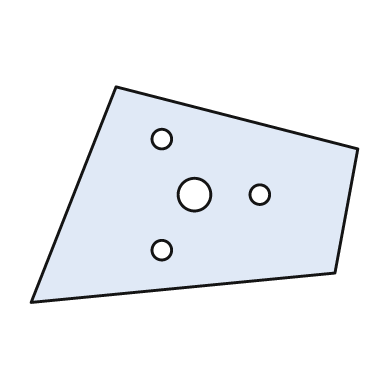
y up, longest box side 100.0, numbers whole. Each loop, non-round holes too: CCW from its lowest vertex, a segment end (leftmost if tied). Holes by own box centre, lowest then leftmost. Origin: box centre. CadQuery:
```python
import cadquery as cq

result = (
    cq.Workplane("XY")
    .moveTo(-50.0, -33.0)
    .lineTo(43.0, -24.0)
    .lineTo(50.0, 14.0)
    .lineTo(-24.0, 33.0)
    .close()
    .moveTo(-10.0, -17.0)
    .circle(3.0)
    .moveTo(0.0, 0.0)
    .circle(5.0)
    .moveTo(20.0, 0.0)
    .circle(3.0)
    .moveTo(-10.0, 17.0)
    .circle(3.0)
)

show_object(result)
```